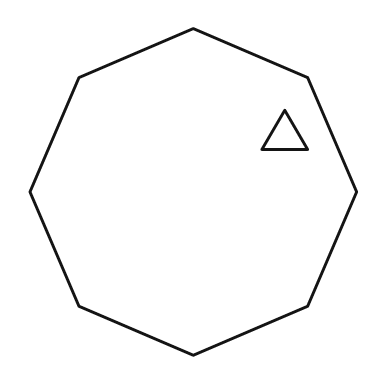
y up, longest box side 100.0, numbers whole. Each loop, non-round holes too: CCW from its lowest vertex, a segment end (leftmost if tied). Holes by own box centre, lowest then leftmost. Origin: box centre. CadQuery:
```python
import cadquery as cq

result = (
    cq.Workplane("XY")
    .moveTo(0.0, -50.0)
    .lineTo(35.0, -35.0)
    .lineTo(50.0, 0.0)
    .lineTo(35.0, 35.0)
    .lineTo(0.0, 50.0)
    .lineTo(-35.0, 35.0)
    .lineTo(-50.0, 0.0)
    .lineTo(-35.0, -35.0)
    .close()
    .moveTo(21.0, 13.0)
    .lineTo(35.0, 13.0)
    .lineTo(28.0, 25.0)
    .close()
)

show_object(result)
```